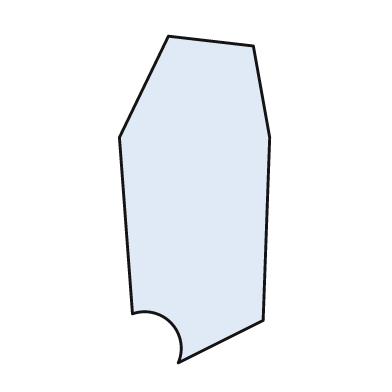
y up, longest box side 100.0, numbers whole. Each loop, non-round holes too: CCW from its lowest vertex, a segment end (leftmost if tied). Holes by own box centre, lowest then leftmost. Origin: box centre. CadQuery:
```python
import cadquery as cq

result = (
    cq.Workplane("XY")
    .moveTo(-5.0, -50.0)
    .lineTo(21.0, -37.0)
    .lineTo(23.0, 19.0)
    .lineTo(18.0, 47.0)
    .lineTo(-8.0, 50.0)
    .lineTo(-23.0, 19.0)
    .lineTo(-19.0, -35.0)
    .threePointArc((-7.0, -38.0), (-5.0, -50.0))
    .close()
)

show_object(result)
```